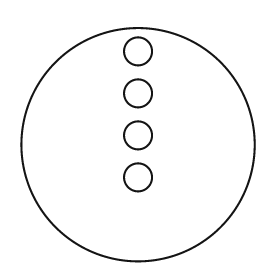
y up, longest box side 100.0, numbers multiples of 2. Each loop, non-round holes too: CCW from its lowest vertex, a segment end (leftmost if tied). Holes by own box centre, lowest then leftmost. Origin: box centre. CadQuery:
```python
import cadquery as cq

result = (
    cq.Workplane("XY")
    .moveTo(0.0, 0.0)
    .circle(50.0)
    .moveTo(0.0, -14.0)
    .circle(6.0)
    .moveTo(0.0, 4.0)
    .circle(6.0)
    .moveTo(0.0, 22.0)
    .circle(6.0)
    .moveTo(0.0, 40.0)
    .circle(6.0)
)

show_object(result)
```